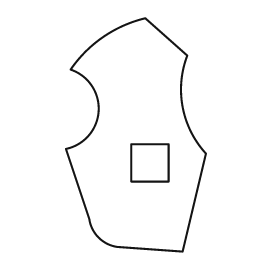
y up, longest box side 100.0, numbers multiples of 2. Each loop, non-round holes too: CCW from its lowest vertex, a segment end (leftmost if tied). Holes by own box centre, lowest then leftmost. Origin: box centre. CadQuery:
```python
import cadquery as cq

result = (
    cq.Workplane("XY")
    .moveTo(20.0, -50.0)
    .lineTo(30.0, -8.0)
    .threePointArc((20.0, 12.0), (22.0, 34.0))
    .lineTo(4.0, 50.0)
    .threePointArc((-14.0, 42.0), (-28.0, 28.0))
    .threePointArc((-16.0, 10.0), (-30.0, -6.0))
    .lineTo(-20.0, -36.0)
    .threePointArc((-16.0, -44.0), (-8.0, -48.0))
    .close()
    .moveTo(-2.0, -20.0)
    .lineTo(14.0, -20.0)
    .lineTo(14.0, -4.0)
    .lineTo(-2.0, -4.0)
    .close()
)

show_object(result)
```